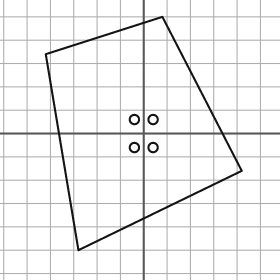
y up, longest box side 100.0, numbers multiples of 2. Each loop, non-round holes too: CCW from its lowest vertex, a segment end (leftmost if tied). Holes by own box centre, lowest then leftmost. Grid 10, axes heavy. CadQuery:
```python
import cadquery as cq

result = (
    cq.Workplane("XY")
    .moveTo(-28.0, -50.0)
    .lineTo(42.0, -16.0)
    .lineTo(8.0, 50.0)
    .lineTo(-42.0, 34.0)
    .close()
    .moveTo(-4.0, -6.0)
    .circle(2.0)
    .moveTo(4.0, -6.0)
    .circle(2.0)
    .moveTo(-4.0, 6.0)
    .circle(2.0)
    .moveTo(4.0, 6.0)
    .circle(2.0)
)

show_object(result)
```